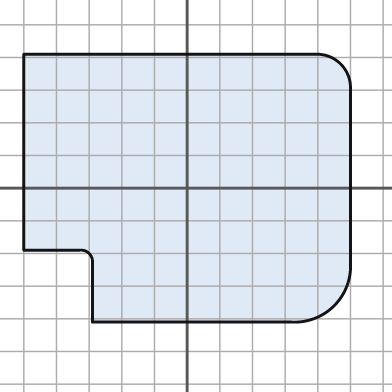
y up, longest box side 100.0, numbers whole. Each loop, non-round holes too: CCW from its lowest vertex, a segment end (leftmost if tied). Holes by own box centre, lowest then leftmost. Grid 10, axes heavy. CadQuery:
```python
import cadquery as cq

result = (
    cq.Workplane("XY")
    .moveTo(-29.0, -41.0)
    .lineTo(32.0, -41.0)
    .threePointArc((45.0, -36.0), (50.0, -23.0))
    .lineTo(50.0, 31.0)
    .threePointArc((47.0, 38.0), (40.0, 41.0))
    .lineTo(-50.0, 41.0)
    .lineTo(-50.0, -19.0)
    .lineTo(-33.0, -19.0)
    .threePointArc((-30.0, -20.0), (-29.0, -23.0))
    .close()
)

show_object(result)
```